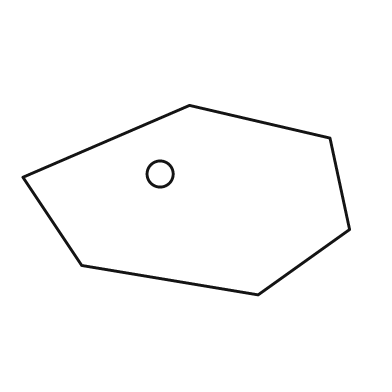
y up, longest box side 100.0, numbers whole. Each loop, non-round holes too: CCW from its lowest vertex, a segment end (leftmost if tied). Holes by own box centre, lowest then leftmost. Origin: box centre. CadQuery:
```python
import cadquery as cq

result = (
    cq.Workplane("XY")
    .moveTo(22.0, -29.0)
    .lineTo(50.0, -9.0)
    .lineTo(44.0, 19.0)
    .lineTo(1.0, 29.0)
    .lineTo(-50.0, 7.0)
    .lineTo(-32.0, -20.0)
    .close()
    .moveTo(-8.0, 8.0)
    .circle(4.0)
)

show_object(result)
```